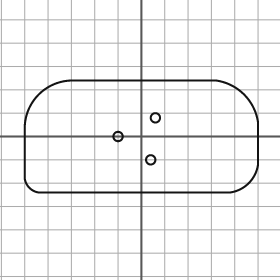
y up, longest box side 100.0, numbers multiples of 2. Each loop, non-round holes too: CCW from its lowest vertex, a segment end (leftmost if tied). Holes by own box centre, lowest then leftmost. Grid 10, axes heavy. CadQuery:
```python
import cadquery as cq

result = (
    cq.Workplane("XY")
    .moveTo(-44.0, -24.0)
    .lineTo(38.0, -24.0)
    .threePointArc((46.0, -20.0), (50.0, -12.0))
    .lineTo(50.0, 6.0)
    .threePointArc((44.0, 18.0), (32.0, 24.0))
    .lineTo(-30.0, 24.0)
    .threePointArc((-44.0, 18.0), (-50.0, 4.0))
    .lineTo(-50.0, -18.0)
    .threePointArc((-48.0, -22.0), (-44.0, -24.0))
    .close()
    .moveTo(4.0, -10.0)
    .circle(2.0)
    .moveTo(-10.0, 0.0)
    .circle(2.0)
    .moveTo(6.0, 8.0)
    .circle(2.0)
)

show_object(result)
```